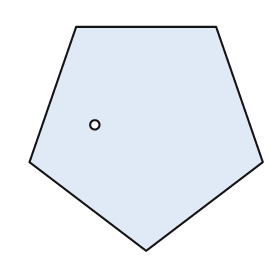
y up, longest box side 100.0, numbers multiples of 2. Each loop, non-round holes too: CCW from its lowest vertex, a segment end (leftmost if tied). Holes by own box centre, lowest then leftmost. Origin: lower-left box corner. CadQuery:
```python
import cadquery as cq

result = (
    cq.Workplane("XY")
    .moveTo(50.0, 0.0)
    .lineTo(100.0, 38.0)
    .lineTo(80.0, 96.0)
    .lineTo(20.0, 96.0)
    .lineTo(0.0, 38.0)
    .close()
    .moveTo(28.0, 54.0)
    .circle(2.0)
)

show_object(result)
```